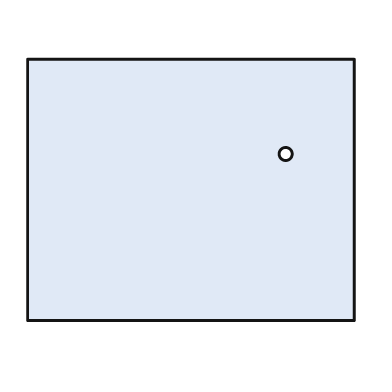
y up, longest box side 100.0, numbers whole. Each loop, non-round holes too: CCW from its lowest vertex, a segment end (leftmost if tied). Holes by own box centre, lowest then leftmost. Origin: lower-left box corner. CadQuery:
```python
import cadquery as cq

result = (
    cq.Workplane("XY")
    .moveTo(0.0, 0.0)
    .lineTo(100.0, 0.0)
    .lineTo(100.0, 80.0)
    .lineTo(0.0, 80.0)
    .close()
    .moveTo(79.0, 51.0)
    .circle(2.0)
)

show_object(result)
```